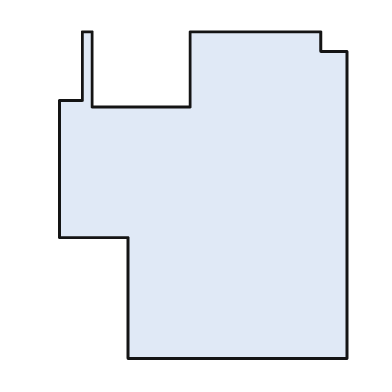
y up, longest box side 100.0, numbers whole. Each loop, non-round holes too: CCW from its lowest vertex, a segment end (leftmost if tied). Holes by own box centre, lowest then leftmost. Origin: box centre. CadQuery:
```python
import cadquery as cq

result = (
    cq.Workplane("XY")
    .moveTo(-23.0, -50.0)
    .lineTo(44.0, -50.0)
    .lineTo(44.0, 44.0)
    .lineTo(36.0, 44.0)
    .lineTo(36.0, 50.0)
    .lineTo(-4.0, 50.0)
    .lineTo(-4.0, 27.0)
    .lineTo(-34.0, 27.0)
    .lineTo(-34.0, 50.0)
    .lineTo(-37.0, 50.0)
    .lineTo(-37.0, 29.0)
    .lineTo(-44.0, 29.0)
    .lineTo(-44.0, -13.0)
    .lineTo(-23.0, -13.0)
    .close()
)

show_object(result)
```